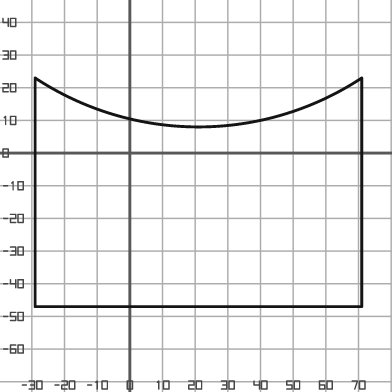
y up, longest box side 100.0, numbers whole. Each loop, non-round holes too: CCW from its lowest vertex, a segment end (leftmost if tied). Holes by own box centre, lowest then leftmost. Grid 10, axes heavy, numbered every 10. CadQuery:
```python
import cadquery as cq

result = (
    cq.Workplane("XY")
    .moveTo(-29.0, -47.0)
    .lineTo(71.0, -47.0)
    .lineTo(71.0, 23.0)
    .threePointArc((21.0, 8.0), (-29.0, 23.0))
    .close()
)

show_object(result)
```